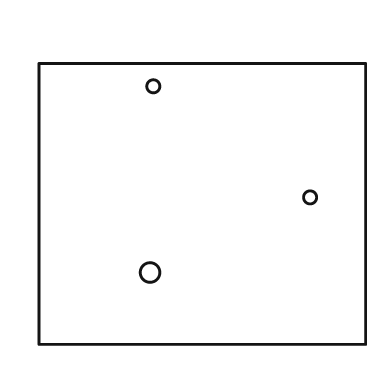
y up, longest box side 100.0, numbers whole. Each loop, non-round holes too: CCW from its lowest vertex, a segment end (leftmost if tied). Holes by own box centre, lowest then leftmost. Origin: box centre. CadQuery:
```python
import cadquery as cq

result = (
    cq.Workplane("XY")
    .moveTo(-50.0, -43.0)
    .lineTo(50.0, -43.0)
    .lineTo(50.0, 43.0)
    .lineTo(-50.0, 43.0)
    .close()
    .moveTo(-16.0, -21.0)
    .circle(3.0)
    .moveTo(33.0, 2.0)
    .circle(2.0)
    .moveTo(-15.0, 36.0)
    .circle(2.0)
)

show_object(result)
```